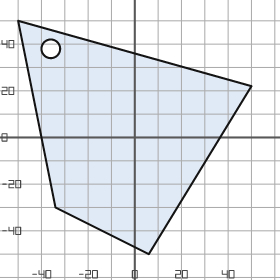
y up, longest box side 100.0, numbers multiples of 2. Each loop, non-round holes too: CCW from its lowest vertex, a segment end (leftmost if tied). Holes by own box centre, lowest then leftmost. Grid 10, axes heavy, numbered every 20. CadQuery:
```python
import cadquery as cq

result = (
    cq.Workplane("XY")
    .moveTo(6.0, -50.0)
    .lineTo(50.0, 22.0)
    .lineTo(-50.0, 50.0)
    .lineTo(-34.0, -30.0)
    .close()
    .moveTo(-36.0, 38.0)
    .circle(4.0)
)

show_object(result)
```